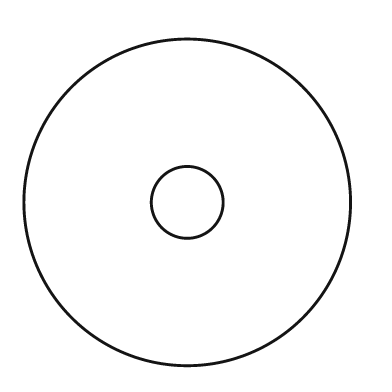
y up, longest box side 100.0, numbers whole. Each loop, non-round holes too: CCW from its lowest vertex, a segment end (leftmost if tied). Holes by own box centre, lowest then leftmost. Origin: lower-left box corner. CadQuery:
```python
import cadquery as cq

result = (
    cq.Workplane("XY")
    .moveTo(50.0, 50.0)
    .circle(50.0)
    .moveTo(50.0, 50.0)
    .circle(11.0)
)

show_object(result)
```